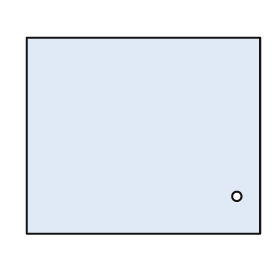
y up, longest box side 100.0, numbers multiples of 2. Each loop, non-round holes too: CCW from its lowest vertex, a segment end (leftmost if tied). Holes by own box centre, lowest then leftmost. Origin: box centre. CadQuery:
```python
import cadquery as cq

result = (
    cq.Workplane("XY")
    .moveTo(-50.0, -42.0)
    .lineTo(50.0, -42.0)
    .lineTo(50.0, 42.0)
    .lineTo(-50.0, 42.0)
    .close()
    .moveTo(40.0, -26.0)
    .circle(2.0)
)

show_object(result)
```